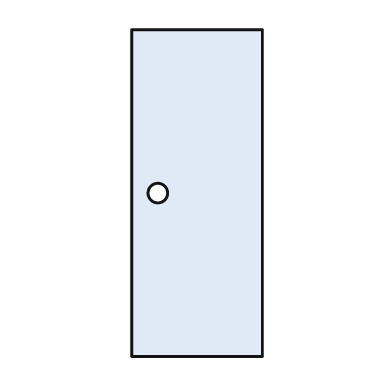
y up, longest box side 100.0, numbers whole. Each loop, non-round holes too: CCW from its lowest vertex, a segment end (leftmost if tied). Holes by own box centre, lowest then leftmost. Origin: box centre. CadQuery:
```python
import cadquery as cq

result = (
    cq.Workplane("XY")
    .moveTo(-20.0, -50.0)
    .lineTo(20.0, -50.0)
    .lineTo(20.0, 50.0)
    .lineTo(-20.0, 50.0)
    .close()
    .moveTo(-12.0, 0.0)
    .circle(3.0)
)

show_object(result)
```